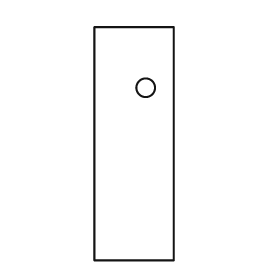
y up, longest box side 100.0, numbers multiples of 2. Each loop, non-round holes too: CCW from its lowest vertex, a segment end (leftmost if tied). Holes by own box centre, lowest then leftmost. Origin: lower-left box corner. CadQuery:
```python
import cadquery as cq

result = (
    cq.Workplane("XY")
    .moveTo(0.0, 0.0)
    .lineTo(34.0, 0.0)
    .lineTo(34.0, 100.0)
    .lineTo(0.0, 100.0)
    .close()
    .moveTo(22.0, 74.0)
    .circle(4.0)
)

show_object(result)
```